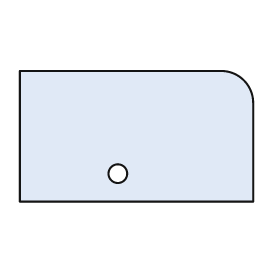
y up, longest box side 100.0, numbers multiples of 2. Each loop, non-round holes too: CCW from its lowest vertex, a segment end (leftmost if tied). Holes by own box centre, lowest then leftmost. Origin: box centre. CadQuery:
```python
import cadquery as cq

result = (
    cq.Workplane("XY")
    .moveTo(-50.0, -28.0)
    .lineTo(50.0, -28.0)
    .lineTo(50.0, 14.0)
    .threePointArc((46.0, 24.0), (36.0, 28.0))
    .lineTo(-50.0, 28.0)
    .close()
    .moveTo(-8.0, -16.0)
    .circle(4.0)
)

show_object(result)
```